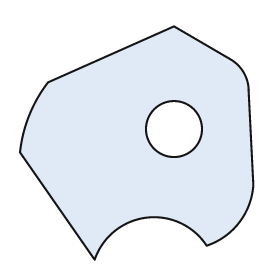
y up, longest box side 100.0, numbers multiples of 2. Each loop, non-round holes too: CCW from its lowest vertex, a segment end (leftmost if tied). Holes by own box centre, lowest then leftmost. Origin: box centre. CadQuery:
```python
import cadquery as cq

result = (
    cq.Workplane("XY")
    .moveTo(-18.0, -50.0)
    .threePointArc((4.0, -32.0), (30.0, -44.0))
    .threePointArc((44.0, -34.0), (50.0, -18.0))
    .lineTo(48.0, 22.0)
    .threePointArc((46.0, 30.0), (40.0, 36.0))
    .lineTo(16.0, 50.0)
    .lineTo(-38.0, 26.0)
    .threePointArc((-46.0, 12.0), (-50.0, -4.0))
    .close()
    .moveTo(16.0, 6.0)
    .circle(12.0)
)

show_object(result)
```